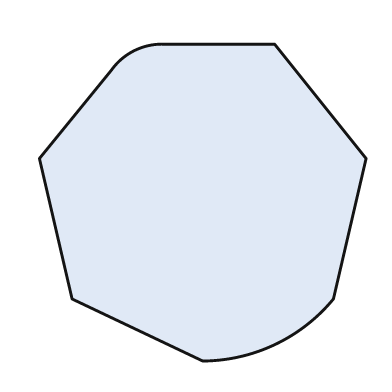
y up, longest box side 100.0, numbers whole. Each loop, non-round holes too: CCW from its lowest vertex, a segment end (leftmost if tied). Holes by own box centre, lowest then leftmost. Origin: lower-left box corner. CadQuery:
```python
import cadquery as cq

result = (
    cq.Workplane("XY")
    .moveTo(50.0, 0.0)
    .threePointArc((72.0, 5.0), (90.0, 19.0))
    .lineTo(100.0, 62.0)
    .lineTo(72.0, 97.0)
    .lineTo(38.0, 97.0)
    .threePointArc((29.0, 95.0), (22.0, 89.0))
    .lineTo(0.0, 62.0)
    .lineTo(10.0, 19.0)
    .close()
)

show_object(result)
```